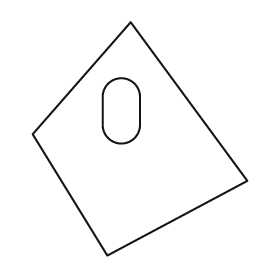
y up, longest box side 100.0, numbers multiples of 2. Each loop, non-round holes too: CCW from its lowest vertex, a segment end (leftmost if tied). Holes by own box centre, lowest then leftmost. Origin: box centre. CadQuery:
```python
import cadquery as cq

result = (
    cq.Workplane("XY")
    .moveTo(-14.0, -50.0)
    .lineTo(46.0, -18.0)
    .lineTo(-4.0, 50.0)
    .lineTo(-46.0, 2.0)
    .close()
    .moveTo(-16.0, 6.0)
    .threePointArc((-8.0, -2.0), (0.0, 6.0))
    .lineTo(0.0, 18.0)
    .threePointArc((-8.0, 26.0), (-16.0, 18.0))
    .close()
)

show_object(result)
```